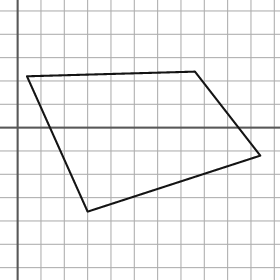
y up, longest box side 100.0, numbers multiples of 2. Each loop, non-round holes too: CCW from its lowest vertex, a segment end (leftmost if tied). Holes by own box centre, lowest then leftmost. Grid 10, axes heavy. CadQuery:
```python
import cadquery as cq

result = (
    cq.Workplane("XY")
    .moveTo(30.0, -36.0)
    .lineTo(104.0, -12.0)
    .lineTo(76.0, 24.0)
    .lineTo(4.0, 22.0)
    .close()
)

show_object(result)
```